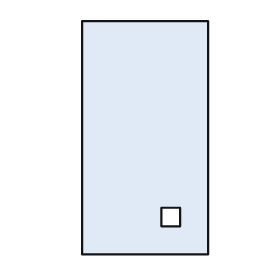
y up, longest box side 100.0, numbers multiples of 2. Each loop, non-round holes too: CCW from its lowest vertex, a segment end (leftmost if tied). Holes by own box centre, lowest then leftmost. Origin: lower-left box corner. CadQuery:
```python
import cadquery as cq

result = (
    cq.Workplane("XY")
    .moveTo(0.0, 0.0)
    .lineTo(54.0, 0.0)
    .lineTo(54.0, 100.0)
    .lineTo(0.0, 100.0)
    .close()
    .moveTo(34.0, 12.0)
    .lineTo(42.0, 12.0)
    .lineTo(42.0, 20.0)
    .lineTo(34.0, 20.0)
    .close()
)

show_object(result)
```